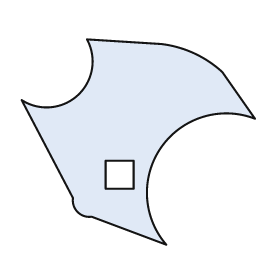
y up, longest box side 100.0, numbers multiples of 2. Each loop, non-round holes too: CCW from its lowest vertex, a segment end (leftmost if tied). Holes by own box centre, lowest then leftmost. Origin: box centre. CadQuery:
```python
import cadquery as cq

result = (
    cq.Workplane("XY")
    .moveTo(12.0, -44.0)
    .threePointArc((10.0, -2.0), (50.0, 10.0))
    .lineTo(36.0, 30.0)
    .threePointArc((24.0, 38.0), (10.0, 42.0))
    .lineTo(-22.0, 44.0)
    .threePointArc((-26.0, 20.0), (-50.0, 18.0))
    .lineTo(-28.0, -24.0)
    .threePointArc((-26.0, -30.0), (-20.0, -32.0))
    .close()
    .moveTo(-14.0, -20.0)
    .lineTo(-2.0, -20.0)
    .lineTo(-2.0, -8.0)
    .lineTo(-14.0, -8.0)
    .close()
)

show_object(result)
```